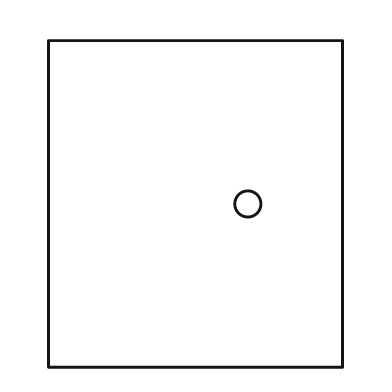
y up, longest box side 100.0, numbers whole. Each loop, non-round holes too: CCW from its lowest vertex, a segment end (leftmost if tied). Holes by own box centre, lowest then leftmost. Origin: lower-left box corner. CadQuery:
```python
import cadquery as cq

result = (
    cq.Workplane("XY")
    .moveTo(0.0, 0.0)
    .lineTo(90.0, 0.0)
    .lineTo(90.0, 100.0)
    .lineTo(0.0, 100.0)
    .close()
    .moveTo(61.0, 50.0)
    .circle(4.0)
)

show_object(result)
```